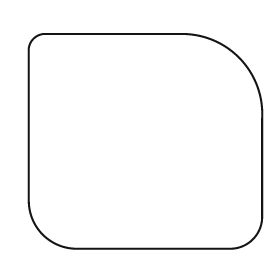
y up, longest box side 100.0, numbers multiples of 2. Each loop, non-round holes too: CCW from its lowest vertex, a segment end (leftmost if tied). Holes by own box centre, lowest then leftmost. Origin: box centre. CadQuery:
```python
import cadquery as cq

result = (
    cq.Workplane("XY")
    .moveTo(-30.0, -46.0)
    .lineTo(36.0, -46.0)
    .threePointArc((46.0, -42.0), (50.0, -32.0))
    .lineTo(50.0, 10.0)
    .threePointArc((40.0, 36.0), (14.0, 46.0))
    .lineTo(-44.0, 46.0)
    .threePointArc((-48.0, 44.0), (-50.0, 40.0))
    .lineTo(-50.0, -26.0)
    .threePointArc((-44.0, -40.0), (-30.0, -46.0))
    .close()
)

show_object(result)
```